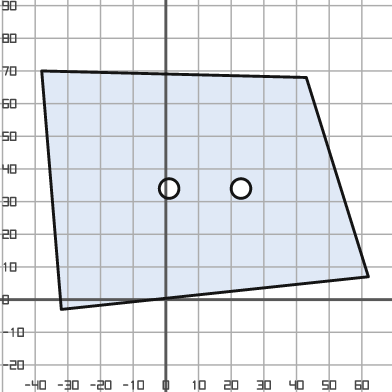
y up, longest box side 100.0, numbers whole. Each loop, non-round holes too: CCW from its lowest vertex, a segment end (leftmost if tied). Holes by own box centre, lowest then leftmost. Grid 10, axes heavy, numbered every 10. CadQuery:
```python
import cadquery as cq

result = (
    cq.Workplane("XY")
    .moveTo(-32.0, -3.0)
    .lineTo(62.0, 7.0)
    .lineTo(43.0, 68.0)
    .lineTo(-38.0, 70.0)
    .close()
    .moveTo(1.0, 34.0)
    .circle(3.0)
    .moveTo(23.0, 34.0)
    .circle(3.0)
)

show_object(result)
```